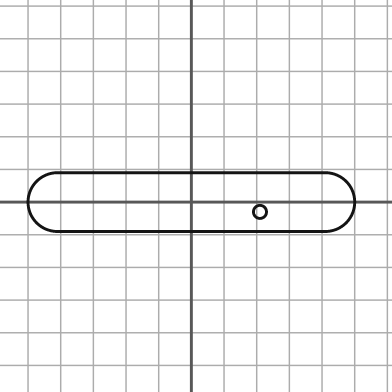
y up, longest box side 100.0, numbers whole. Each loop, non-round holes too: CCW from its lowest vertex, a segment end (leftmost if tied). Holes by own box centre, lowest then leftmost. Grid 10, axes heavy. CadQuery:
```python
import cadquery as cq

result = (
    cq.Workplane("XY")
    .moveTo(-41.0, -9.0)
    .lineTo(41.0, -9.0)
    .threePointArc((50.0, 0.0), (41.0, 9.0))
    .lineTo(-41.0, 9.0)
    .threePointArc((-50.0, 0.0), (-41.0, -9.0))
    .close()
    .moveTo(21.0, -3.0)
    .circle(2.0)
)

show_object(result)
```